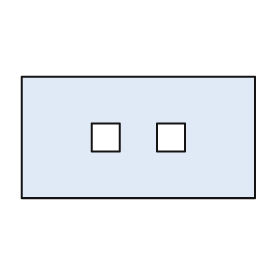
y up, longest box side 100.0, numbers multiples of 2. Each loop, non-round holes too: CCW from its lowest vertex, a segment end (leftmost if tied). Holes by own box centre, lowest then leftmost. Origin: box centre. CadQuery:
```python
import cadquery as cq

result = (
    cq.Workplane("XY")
    .moveTo(-50.0, -26.0)
    .lineTo(50.0, -26.0)
    .lineTo(50.0, 26.0)
    .lineTo(-50.0, 26.0)
    .close()
    .moveTo(-20.0, -6.0)
    .lineTo(-8.0, -6.0)
    .lineTo(-8.0, 6.0)
    .lineTo(-20.0, 6.0)
    .close()
    .moveTo(8.0, -6.0)
    .lineTo(20.0, -6.0)
    .lineTo(20.0, 6.0)
    .lineTo(8.0, 6.0)
    .close()
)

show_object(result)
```